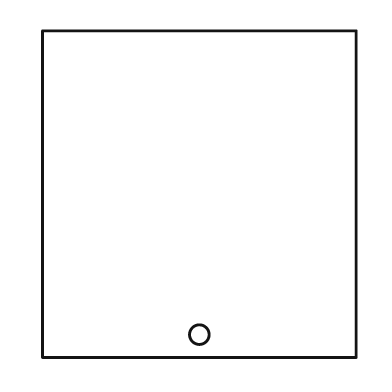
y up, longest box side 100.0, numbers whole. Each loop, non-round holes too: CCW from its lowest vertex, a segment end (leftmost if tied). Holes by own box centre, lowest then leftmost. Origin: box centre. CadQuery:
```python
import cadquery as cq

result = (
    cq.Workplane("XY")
    .moveTo(-48.0, -50.0)
    .lineTo(48.0, -50.0)
    .lineTo(48.0, 50.0)
    .lineTo(-48.0, 50.0)
    .close()
    .moveTo(0.0, -43.0)
    .circle(3.0)
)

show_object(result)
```